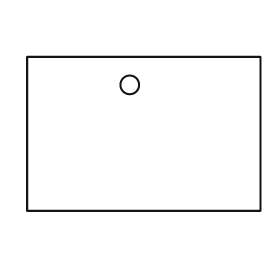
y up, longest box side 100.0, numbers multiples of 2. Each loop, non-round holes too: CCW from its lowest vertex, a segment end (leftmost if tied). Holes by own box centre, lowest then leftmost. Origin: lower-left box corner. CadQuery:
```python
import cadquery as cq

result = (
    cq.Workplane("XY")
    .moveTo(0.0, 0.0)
    .lineTo(100.0, 0.0)
    .lineTo(100.0, 66.0)
    .lineTo(0.0, 66.0)
    .close()
    .moveTo(44.0, 54.0)
    .circle(4.0)
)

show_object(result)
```